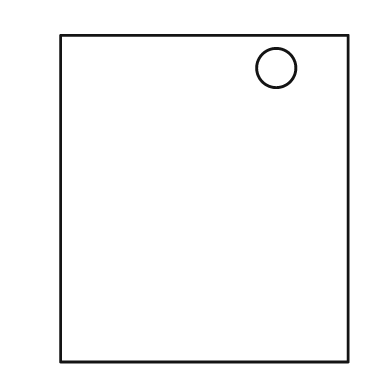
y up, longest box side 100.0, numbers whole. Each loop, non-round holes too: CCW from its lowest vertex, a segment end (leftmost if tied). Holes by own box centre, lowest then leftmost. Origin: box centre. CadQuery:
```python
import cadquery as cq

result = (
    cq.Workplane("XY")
    .moveTo(-44.0, -50.0)
    .lineTo(44.0, -50.0)
    .lineTo(44.0, 50.0)
    .lineTo(-44.0, 50.0)
    .close()
    .moveTo(22.0, 40.0)
    .circle(6.0)
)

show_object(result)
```